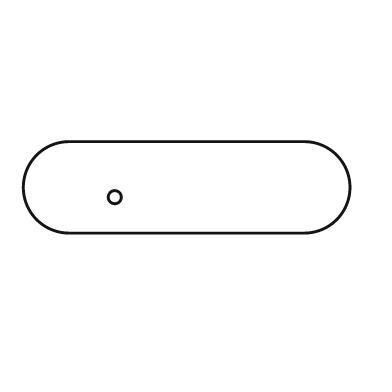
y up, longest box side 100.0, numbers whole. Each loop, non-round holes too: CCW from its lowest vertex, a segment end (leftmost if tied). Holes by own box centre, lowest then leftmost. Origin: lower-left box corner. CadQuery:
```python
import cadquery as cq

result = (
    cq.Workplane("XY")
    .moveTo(14.0, 0.0)
    .lineTo(86.0, 0.0)
    .threePointArc((100.0, 14.0), (86.0, 28.0))
    .lineTo(14.0, 28.0)
    .threePointArc((0.0, 14.0), (14.0, 0.0))
    .close()
    .moveTo(28.0, 11.0)
    .circle(2.0)
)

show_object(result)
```